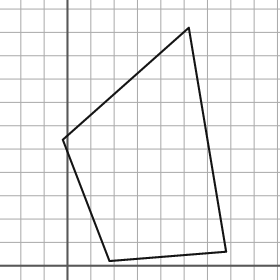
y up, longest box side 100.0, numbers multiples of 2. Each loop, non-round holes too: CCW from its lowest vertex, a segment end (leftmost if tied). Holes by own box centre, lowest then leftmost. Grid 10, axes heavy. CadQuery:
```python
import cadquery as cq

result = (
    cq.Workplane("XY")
    .moveTo(18.0, 2.0)
    .lineTo(68.0, 6.0)
    .lineTo(52.0, 102.0)
    .lineTo(-2.0, 54.0)
    .close()
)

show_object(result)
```